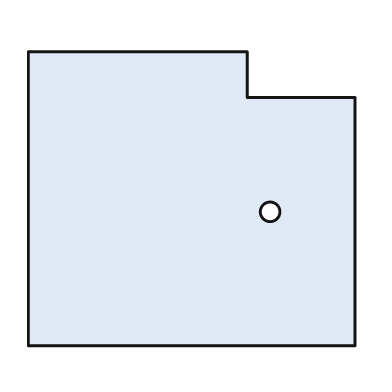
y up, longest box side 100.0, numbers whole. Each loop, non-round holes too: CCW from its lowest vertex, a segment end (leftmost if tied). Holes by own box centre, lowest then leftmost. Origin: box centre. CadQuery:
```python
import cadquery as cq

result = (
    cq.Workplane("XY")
    .moveTo(-50.0, -45.0)
    .lineTo(50.0, -45.0)
    .lineTo(50.0, 31.0)
    .lineTo(17.0, 31.0)
    .lineTo(17.0, 45.0)
    .lineTo(-50.0, 45.0)
    .close()
    .moveTo(24.0, -4.0)
    .circle(3.0)
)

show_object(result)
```